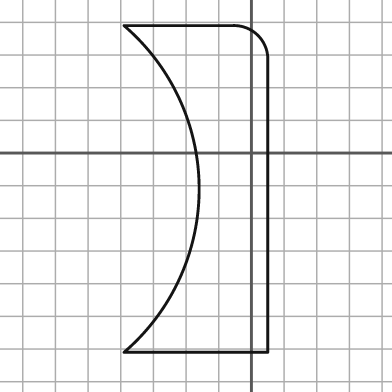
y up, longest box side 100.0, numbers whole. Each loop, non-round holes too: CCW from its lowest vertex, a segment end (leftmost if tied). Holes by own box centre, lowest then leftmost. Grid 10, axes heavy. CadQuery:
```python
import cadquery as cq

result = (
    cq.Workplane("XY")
    .moveTo(-39.0, -61.0)
    .lineTo(5.0, -61.0)
    .lineTo(5.0, 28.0)
    .threePointArc((2.0, 36.0), (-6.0, 39.0))
    .lineTo(-39.0, 39.0)
    .threePointArc((-16.0, -11.0), (-39.0, -61.0))
    .close()
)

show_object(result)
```